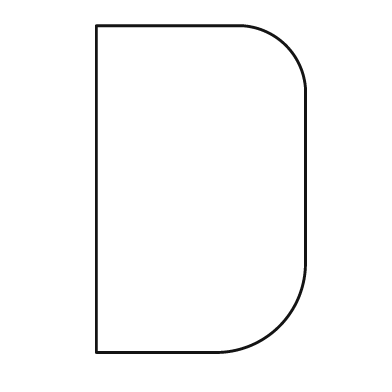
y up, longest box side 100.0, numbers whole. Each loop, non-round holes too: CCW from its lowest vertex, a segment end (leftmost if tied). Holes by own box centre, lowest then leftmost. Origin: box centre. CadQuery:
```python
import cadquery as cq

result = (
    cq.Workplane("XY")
    .moveTo(-32.0, -50.0)
    .lineTo(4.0, -50.0)
    .threePointArc((24.0, -42.0), (32.0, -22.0))
    .lineTo(32.0, 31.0)
    .threePointArc((26.0, 44.0), (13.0, 50.0))
    .lineTo(-32.0, 50.0)
    .close()
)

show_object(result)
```